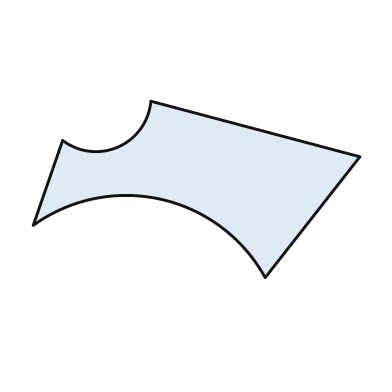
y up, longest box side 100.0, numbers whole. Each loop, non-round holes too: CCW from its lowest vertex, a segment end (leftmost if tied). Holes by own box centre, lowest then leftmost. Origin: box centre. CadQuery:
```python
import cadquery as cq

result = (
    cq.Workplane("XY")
    .moveTo(21.0, -27.0)
    .lineTo(50.0, 10.0)
    .lineTo(-14.0, 27.0)
    .threePointArc((-24.0, 13.0), (-41.0, 15.0))
    .lineTo(-50.0, -11.0)
    .threePointArc((-11.0, -3.0), (21.0, -27.0))
    .close()
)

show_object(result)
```